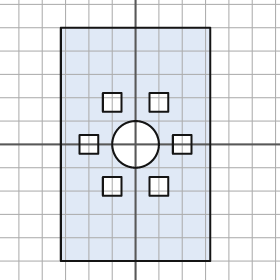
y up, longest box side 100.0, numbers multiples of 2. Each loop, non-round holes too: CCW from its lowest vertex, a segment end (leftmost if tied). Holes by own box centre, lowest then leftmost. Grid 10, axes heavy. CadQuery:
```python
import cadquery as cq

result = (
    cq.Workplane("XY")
    .moveTo(-32.0, -50.0)
    .lineTo(32.0, -50.0)
    .lineTo(32.0, 50.0)
    .lineTo(-32.0, 50.0)
    .close()
    .moveTo(-14.0, -22.0)
    .lineTo(-6.0, -22.0)
    .lineTo(-6.0, -14.0)
    .lineTo(-14.0, -14.0)
    .close()
    .moveTo(6.0, -22.0)
    .lineTo(14.0, -22.0)
    .lineTo(14.0, -14.0)
    .lineTo(6.0, -14.0)
    .close()
    .moveTo(-24.0, -4.0)
    .lineTo(-16.0, -4.0)
    .lineTo(-16.0, 4.0)
    .lineTo(-24.0, 4.0)
    .close()
    .moveTo(0.0, 0.0)
    .circle(10.0)
    .moveTo(16.0, -4.0)
    .lineTo(24.0, -4.0)
    .lineTo(24.0, 4.0)
    .lineTo(16.0, 4.0)
    .close()
    .moveTo(-14.0, 14.0)
    .lineTo(-6.0, 14.0)
    .lineTo(-6.0, 22.0)
    .lineTo(-14.0, 22.0)
    .close()
    .moveTo(6.0, 14.0)
    .lineTo(14.0, 14.0)
    .lineTo(14.0, 22.0)
    .lineTo(6.0, 22.0)
    .close()
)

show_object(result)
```